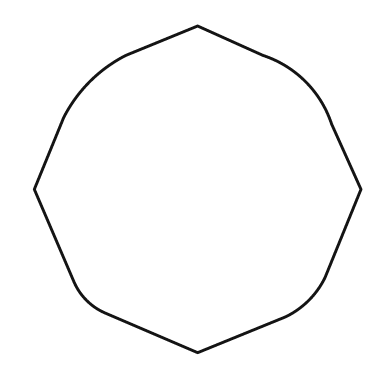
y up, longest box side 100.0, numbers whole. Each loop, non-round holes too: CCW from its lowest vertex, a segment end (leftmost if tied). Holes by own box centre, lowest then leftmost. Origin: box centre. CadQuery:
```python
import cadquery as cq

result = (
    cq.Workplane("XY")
    .moveTo(0.0, -50.0)
    .lineTo(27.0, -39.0)
    .threePointArc((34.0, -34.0), (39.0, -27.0))
    .lineTo(50.0, 0.0)
    .lineTo(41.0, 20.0)
    .threePointArc((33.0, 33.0), (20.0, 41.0))
    .lineTo(0.0, 50.0)
    .lineTo(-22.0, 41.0)
    .threePointArc((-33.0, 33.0), (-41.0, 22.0))
    .lineTo(-50.0, 0.0)
    .lineTo(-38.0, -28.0)
    .threePointArc((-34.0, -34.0), (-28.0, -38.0))
    .close()
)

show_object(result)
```